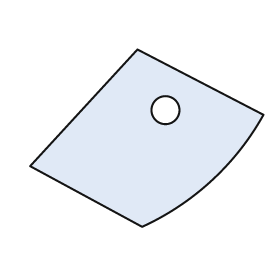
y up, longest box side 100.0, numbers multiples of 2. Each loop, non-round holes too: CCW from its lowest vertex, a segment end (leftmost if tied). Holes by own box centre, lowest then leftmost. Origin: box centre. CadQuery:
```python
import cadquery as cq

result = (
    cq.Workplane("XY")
    .moveTo(-2.0, -38.0)
    .threePointArc((28.0, -18.0), (50.0, 10.0))
    .lineTo(-4.0, 38.0)
    .lineTo(-50.0, -12.0)
    .close()
    .moveTo(8.0, 12.0)
    .circle(6.0)
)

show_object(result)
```